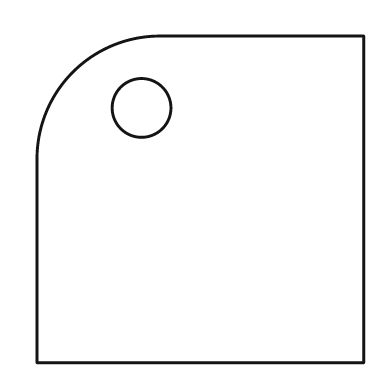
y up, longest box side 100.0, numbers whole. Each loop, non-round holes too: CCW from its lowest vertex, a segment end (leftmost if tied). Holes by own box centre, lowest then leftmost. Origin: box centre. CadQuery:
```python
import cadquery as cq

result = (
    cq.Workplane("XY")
    .moveTo(-50.0, -50.0)
    .lineTo(50.0, -50.0)
    .lineTo(50.0, 50.0)
    .lineTo(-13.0, 50.0)
    .threePointArc((-39.0, 39.0), (-50.0, 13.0))
    .close()
    .moveTo(-18.0, 28.0)
    .circle(9.0)
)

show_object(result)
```